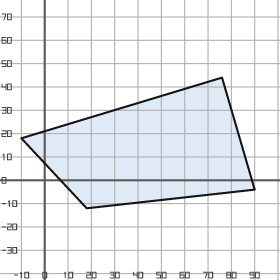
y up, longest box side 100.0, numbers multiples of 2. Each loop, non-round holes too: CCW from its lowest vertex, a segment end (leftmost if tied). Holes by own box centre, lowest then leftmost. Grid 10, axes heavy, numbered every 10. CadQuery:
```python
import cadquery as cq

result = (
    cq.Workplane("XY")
    .moveTo(18.0, -12.0)
    .lineTo(90.0, -4.0)
    .lineTo(76.0, 44.0)
    .lineTo(-10.0, 18.0)
    .close()
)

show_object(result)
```